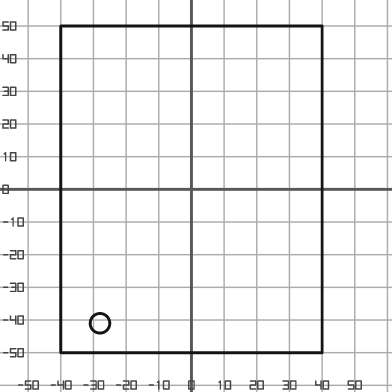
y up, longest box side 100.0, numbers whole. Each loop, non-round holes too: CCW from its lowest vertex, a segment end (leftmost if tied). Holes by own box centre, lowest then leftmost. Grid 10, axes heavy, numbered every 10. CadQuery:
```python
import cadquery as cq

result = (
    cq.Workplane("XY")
    .moveTo(-40.0, -50.0)
    .lineTo(40.0, -50.0)
    .lineTo(40.0, 50.0)
    .lineTo(-40.0, 50.0)
    .close()
    .moveTo(-28.0, -41.0)
    .circle(3.0)
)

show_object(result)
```